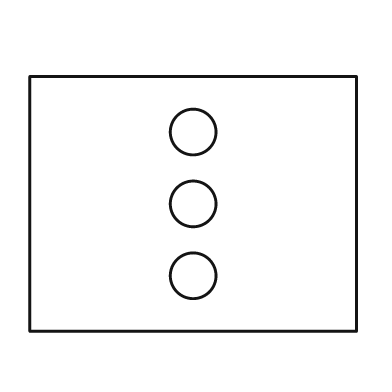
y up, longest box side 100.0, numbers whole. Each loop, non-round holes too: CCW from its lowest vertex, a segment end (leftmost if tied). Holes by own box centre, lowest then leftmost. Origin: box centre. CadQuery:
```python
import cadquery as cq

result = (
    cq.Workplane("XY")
    .moveTo(-50.0, -39.0)
    .lineTo(50.0, -39.0)
    .lineTo(50.0, 39.0)
    .lineTo(-50.0, 39.0)
    .close()
    .moveTo(0.0, -22.0)
    .circle(7.0)
    .moveTo(0.0, 0.0)
    .circle(7.0)
    .moveTo(0.0, 22.0)
    .circle(7.0)
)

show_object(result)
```